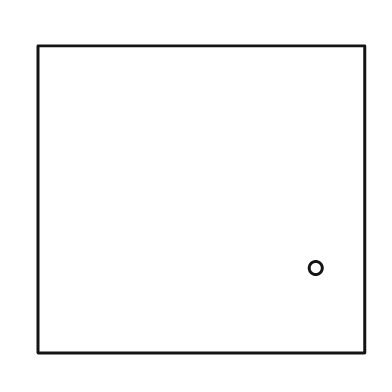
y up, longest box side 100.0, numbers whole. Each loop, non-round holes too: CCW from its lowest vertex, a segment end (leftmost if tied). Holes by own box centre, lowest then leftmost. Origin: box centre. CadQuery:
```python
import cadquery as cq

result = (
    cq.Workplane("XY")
    .moveTo(-50.0, -47.0)
    .lineTo(50.0, -47.0)
    .lineTo(50.0, 47.0)
    .lineTo(-50.0, 47.0)
    .close()
    .moveTo(35.0, -21.0)
    .circle(2.0)
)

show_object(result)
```